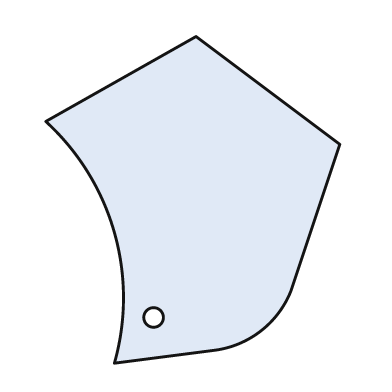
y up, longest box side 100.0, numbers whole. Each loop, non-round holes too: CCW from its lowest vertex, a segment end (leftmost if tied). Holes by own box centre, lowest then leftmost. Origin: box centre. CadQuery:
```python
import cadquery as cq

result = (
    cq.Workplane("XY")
    .moveTo(-24.0, -50.0)
    .lineTo(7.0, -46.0)
    .threePointArc((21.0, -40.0), (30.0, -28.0))
    .lineTo(45.0, 17.0)
    .lineTo(1.0, 50.0)
    .lineTo(-45.0, 24.0)
    .threePointArc((-24.0, -10.0), (-24.0, -50.0))
    .close()
    .moveTo(-12.0, -36.0)
    .circle(3.0)
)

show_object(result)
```